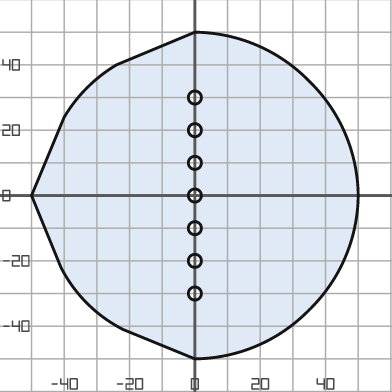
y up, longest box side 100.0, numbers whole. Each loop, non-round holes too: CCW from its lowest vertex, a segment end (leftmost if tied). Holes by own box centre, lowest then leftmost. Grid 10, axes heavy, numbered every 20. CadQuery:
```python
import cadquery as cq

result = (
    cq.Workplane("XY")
    .moveTo(0.0, -50.0)
    .threePointArc((19.0, -46.0), (35.0, -35.0))
    .threePointArc((46.0, -19.0), (50.0, 0.0))
    .threePointArc((46.0, 19.0), (35.0, 35.0))
    .threePointArc((19.0, 46.0), (0.0, 50.0))
    .lineTo(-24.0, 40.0)
    .threePointArc((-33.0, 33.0), (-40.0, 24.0))
    .lineTo(-50.0, 0.0)
    .lineTo(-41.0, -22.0)
    .threePointArc((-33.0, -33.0), (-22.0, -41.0))
    .close()
    .moveTo(0.0, -30.0)
    .circle(2.0)
    .moveTo(0.0, -20.0)
    .circle(2.0)
    .moveTo(0.0, -10.0)
    .circle(2.0)
    .moveTo(0.0, 0.0)
    .circle(2.0)
    .moveTo(0.0, 10.0)
    .circle(2.0)
    .moveTo(0.0, 20.0)
    .circle(2.0)
    .moveTo(0.0, 30.0)
    .circle(2.0)
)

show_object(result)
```